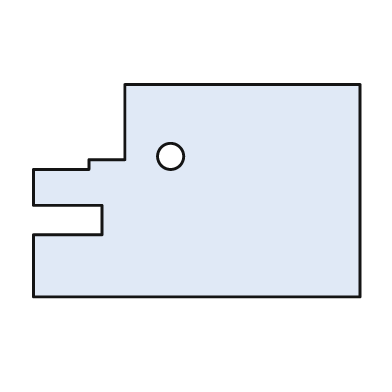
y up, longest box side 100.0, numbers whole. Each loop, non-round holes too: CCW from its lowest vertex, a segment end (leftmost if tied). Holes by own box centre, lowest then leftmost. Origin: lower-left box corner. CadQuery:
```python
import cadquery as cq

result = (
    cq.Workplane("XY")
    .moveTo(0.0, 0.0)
    .lineTo(100.0, 0.0)
    .lineTo(100.0, 65.0)
    .lineTo(28.0, 65.0)
    .lineTo(28.0, 42.0)
    .lineTo(17.0, 42.0)
    .lineTo(17.0, 39.0)
    .lineTo(0.0, 39.0)
    .lineTo(0.0, 28.0)
    .lineTo(21.0, 28.0)
    .lineTo(21.0, 19.0)
    .lineTo(0.0, 19.0)
    .close()
    .moveTo(42.0, 43.0)
    .circle(4.0)
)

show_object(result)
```